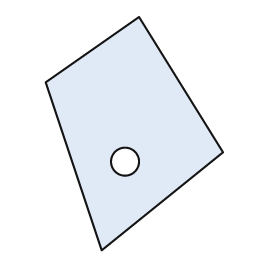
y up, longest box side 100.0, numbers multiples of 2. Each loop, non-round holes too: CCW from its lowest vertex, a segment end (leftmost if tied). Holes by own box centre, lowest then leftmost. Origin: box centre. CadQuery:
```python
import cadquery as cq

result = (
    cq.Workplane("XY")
    .moveTo(-14.0, -50.0)
    .lineTo(38.0, -8.0)
    .lineTo(2.0, 50.0)
    .lineTo(-38.0, 22.0)
    .close()
    .moveTo(-4.0, -12.0)
    .circle(6.0)
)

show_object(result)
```